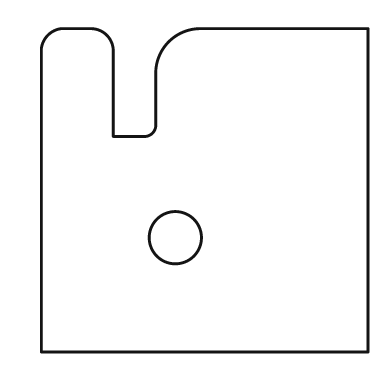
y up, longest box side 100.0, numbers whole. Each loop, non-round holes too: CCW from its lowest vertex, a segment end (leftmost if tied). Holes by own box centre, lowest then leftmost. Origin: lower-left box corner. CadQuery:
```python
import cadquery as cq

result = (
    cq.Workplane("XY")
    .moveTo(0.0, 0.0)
    .lineTo(100.0, 0.0)
    .lineTo(100.0, 99.0)
    .lineTo(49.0, 99.0)
    .threePointArc((39.0, 95.0), (35.0, 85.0))
    .lineTo(35.0, 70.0)
    .threePointArc((34.0, 67.0), (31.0, 66.0))
    .lineTo(22.0, 66.0)
    .lineTo(22.0, 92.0)
    .threePointArc((20.0, 97.0), (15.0, 99.0))
    .lineTo(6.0, 99.0)
    .threePointArc((2.0, 97.0), (0.0, 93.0))
    .close()
    .moveTo(41.0, 35.0)
    .circle(8.0)
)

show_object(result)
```